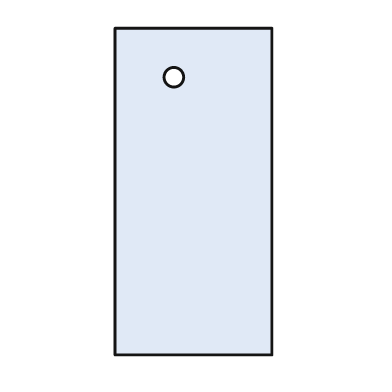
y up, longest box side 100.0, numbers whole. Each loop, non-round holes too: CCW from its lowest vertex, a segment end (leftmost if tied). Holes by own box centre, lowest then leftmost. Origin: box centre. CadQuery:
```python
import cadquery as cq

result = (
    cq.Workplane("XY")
    .moveTo(-24.0, -50.0)
    .lineTo(24.0, -50.0)
    .lineTo(24.0, 50.0)
    .lineTo(-24.0, 50.0)
    .close()
    .moveTo(-6.0, 35.0)
    .circle(3.0)
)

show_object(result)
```